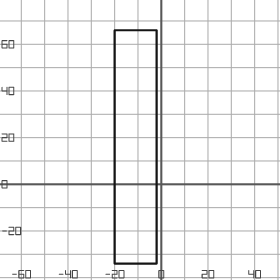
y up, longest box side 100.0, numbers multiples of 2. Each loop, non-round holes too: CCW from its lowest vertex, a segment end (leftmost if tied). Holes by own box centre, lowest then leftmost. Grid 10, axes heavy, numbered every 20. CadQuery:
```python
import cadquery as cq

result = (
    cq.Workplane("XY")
    .moveTo(-20.0, -34.0)
    .lineTo(-2.0, -34.0)
    .lineTo(-2.0, 66.0)
    .lineTo(-20.0, 66.0)
    .close()
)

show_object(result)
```